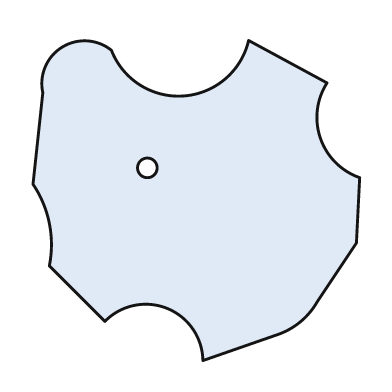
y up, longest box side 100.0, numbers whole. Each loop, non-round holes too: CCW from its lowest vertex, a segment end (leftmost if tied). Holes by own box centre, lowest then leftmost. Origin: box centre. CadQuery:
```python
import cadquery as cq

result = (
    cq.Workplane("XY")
    .moveTo(2.0, -49.0)
    .lineTo(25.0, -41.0)
    .threePointArc((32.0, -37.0), (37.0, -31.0))
    .lineTo(49.0, -13.0)
    .lineTo(50.0, 7.0)
    .threePointArc((38.0, 19.0), (40.0, 36.0))
    .lineTo(16.0, 49.0)
    .threePointArc((-4.0, 32.0), (-26.0, 46.0))
    .threePointArc((-41.0, 47.0), (-47.0, 33.0))
    .lineTo(-50.0, 5.0)
    .threePointArc((-45.0, -7.0), (-45.0, -20.0))
    .lineTo(-28.0, -37.0)
    .threePointArc((-9.0, -33.0), (2.0, -49.0))
    .close()
    .moveTo(-15.0, 10.0)
    .circle(3.0)
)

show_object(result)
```